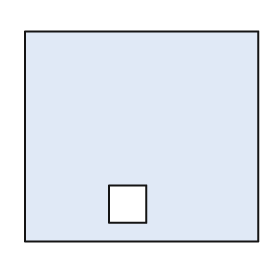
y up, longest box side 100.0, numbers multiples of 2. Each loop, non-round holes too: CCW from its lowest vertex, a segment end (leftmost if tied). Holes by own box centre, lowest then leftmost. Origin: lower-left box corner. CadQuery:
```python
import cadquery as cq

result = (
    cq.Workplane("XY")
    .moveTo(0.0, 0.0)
    .lineTo(100.0, 0.0)
    .lineTo(100.0, 90.0)
    .lineTo(0.0, 90.0)
    .close()
    .moveTo(36.0, 8.0)
    .lineTo(52.0, 8.0)
    .lineTo(52.0, 24.0)
    .lineTo(36.0, 24.0)
    .close()
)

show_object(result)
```